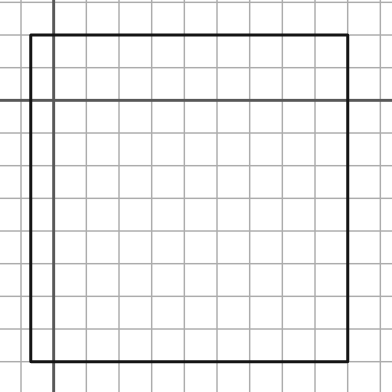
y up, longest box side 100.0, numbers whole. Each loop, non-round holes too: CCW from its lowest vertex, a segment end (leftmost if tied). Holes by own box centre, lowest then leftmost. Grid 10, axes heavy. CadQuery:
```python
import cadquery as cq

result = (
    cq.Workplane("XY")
    .moveTo(-7.0, -80.0)
    .lineTo(90.0, -80.0)
    .lineTo(90.0, 20.0)
    .lineTo(-7.0, 20.0)
    .close()
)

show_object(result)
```